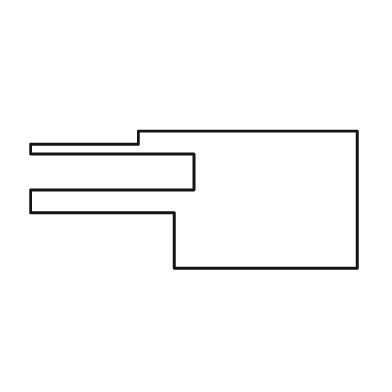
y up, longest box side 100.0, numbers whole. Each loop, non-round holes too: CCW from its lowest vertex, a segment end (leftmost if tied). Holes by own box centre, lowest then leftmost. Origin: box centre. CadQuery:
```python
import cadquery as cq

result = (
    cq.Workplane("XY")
    .moveTo(-6.0, -21.0)
    .lineTo(50.0, -21.0)
    .lineTo(50.0, 21.0)
    .lineTo(-17.0, 21.0)
    .lineTo(-17.0, 17.0)
    .lineTo(-50.0, 17.0)
    .lineTo(-50.0, 14.0)
    .lineTo(0.0, 14.0)
    .lineTo(0.0, 3.0)
    .lineTo(-50.0, 3.0)
    .lineTo(-50.0, -4.0)
    .lineTo(-6.0, -4.0)
    .close()
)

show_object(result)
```